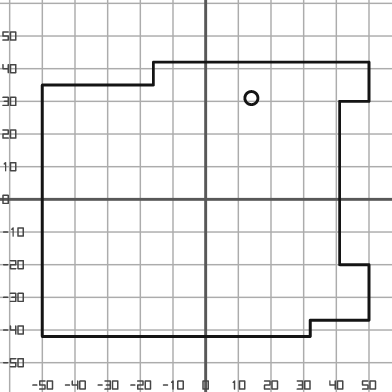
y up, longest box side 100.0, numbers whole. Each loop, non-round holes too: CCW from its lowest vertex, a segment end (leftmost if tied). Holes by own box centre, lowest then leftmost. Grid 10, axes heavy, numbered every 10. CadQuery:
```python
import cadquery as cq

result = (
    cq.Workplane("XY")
    .moveTo(-50.0, -42.0)
    .lineTo(32.0, -42.0)
    .lineTo(32.0, -37.0)
    .lineTo(50.0, -37.0)
    .lineTo(50.0, -20.0)
    .lineTo(41.0, -20.0)
    .lineTo(41.0, 30.0)
    .lineTo(50.0, 30.0)
    .lineTo(50.0, 42.0)
    .lineTo(-16.0, 42.0)
    .lineTo(-16.0, 35.0)
    .lineTo(-50.0, 35.0)
    .close()
    .moveTo(14.0, 31.0)
    .circle(2.0)
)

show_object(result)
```